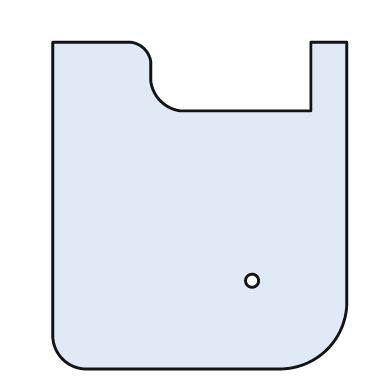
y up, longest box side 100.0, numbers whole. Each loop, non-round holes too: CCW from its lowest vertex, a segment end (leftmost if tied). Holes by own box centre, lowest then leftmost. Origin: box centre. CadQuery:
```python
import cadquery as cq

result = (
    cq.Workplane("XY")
    .moveTo(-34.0, -50.0)
    .lineTo(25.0, -50.0)
    .threePointArc((39.0, -44.0), (45.0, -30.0))
    .lineTo(45.0, 50.0)
    .lineTo(34.0, 50.0)
    .lineTo(34.0, 29.0)
    .lineTo(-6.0, 29.0)
    .threePointArc((-12.0, 32.0), (-15.0, 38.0))
    .lineTo(-15.0, 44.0)
    .threePointArc((-17.0, 48.0), (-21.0, 50.0))
    .lineTo(-45.0, 50.0)
    .lineTo(-45.0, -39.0)
    .threePointArc((-42.0, -47.0), (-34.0, -50.0))
    .close()
    .moveTo(16.0, -23.0)
    .circle(2.0)
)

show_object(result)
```